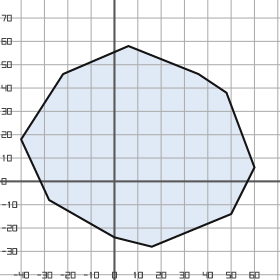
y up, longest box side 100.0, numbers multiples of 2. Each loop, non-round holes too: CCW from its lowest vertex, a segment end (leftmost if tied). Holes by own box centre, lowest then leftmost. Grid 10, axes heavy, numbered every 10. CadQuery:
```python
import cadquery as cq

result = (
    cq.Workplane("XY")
    .moveTo(16.0, -28.0)
    .lineTo(50.0, -14.0)
    .lineTo(60.0, 6.0)
    .lineTo(48.0, 38.0)
    .lineTo(36.0, 46.0)
    .lineTo(6.0, 58.0)
    .lineTo(-22.0, 46.0)
    .lineTo(-40.0, 18.0)
    .lineTo(-28.0, -8.0)
    .lineTo(0.0, -24.0)
    .close()
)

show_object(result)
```